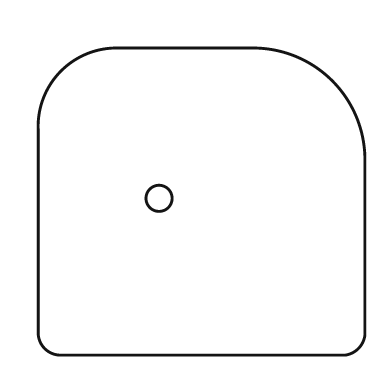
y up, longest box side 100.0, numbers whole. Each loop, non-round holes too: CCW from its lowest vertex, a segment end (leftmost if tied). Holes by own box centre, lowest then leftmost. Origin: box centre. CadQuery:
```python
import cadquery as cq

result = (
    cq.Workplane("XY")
    .moveTo(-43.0, -47.0)
    .lineTo(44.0, -47.0)
    .threePointArc((48.0, -45.0), (50.0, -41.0))
    .lineTo(50.0, 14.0)
    .threePointArc((40.0, 37.0), (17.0, 47.0))
    .lineTo(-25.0, 47.0)
    .threePointArc((-43.0, 40.0), (-50.0, 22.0))
    .lineTo(-50.0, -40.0)
    .threePointArc((-48.0, -45.0), (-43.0, -47.0))
    .close()
    .moveTo(-13.0, 1.0)
    .circle(4.0)
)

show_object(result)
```